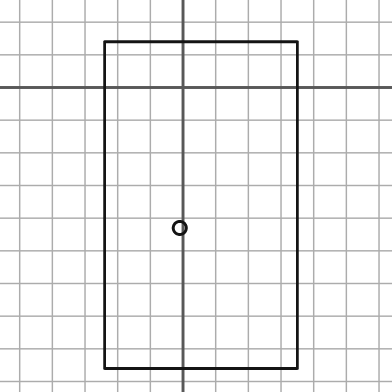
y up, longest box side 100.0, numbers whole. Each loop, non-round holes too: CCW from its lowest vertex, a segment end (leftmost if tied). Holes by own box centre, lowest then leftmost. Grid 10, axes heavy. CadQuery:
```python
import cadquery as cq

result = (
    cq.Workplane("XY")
    .moveTo(-24.0, -86.0)
    .lineTo(35.0, -86.0)
    .lineTo(35.0, 14.0)
    .lineTo(-24.0, 14.0)
    .close()
    .moveTo(-1.0, -43.0)
    .circle(2.0)
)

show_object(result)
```